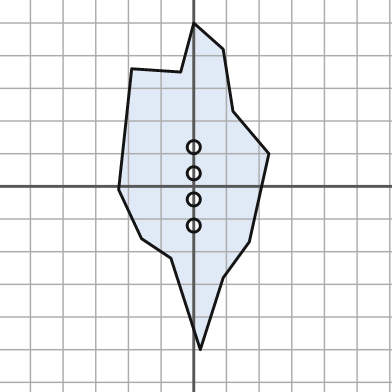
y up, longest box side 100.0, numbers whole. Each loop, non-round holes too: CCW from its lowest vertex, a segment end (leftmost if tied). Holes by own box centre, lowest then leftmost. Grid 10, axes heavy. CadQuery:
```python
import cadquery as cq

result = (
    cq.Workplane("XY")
    .moveTo(2.0, -50.0)
    .lineTo(9.0, -28.0)
    .lineTo(17.0, -17.0)
    .lineTo(23.0, 10.0)
    .lineTo(12.0, 23.0)
    .lineTo(9.0, 42.0)
    .lineTo(0.0, 50.0)
    .lineTo(-4.0, 35.0)
    .lineTo(-19.0, 36.0)
    .lineTo(-23.0, -1.0)
    .lineTo(-16.0, -16.0)
    .lineTo(-7.0, -22.0)
    .close()
    .moveTo(0.0, -12.0)
    .circle(2.0)
    .moveTo(0.0, -4.0)
    .circle(2.0)
    .moveTo(0.0, 4.0)
    .circle(2.0)
    .moveTo(0.0, 12.0)
    .circle(2.0)
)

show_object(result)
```